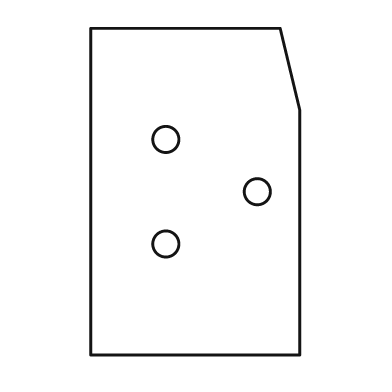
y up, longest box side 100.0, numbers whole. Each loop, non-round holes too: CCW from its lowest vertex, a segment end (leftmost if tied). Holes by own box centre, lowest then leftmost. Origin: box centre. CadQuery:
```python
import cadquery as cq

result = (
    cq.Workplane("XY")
    .moveTo(-32.0, -50.0)
    .lineTo(32.0, -50.0)
    .lineTo(32.0, 25.0)
    .lineTo(26.0, 50.0)
    .lineTo(-32.0, 50.0)
    .close()
    .moveTo(-9.0, -16.0)
    .circle(4.0)
    .moveTo(19.0, 0.0)
    .circle(4.0)
    .moveTo(-9.0, 16.0)
    .circle(4.0)
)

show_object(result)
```